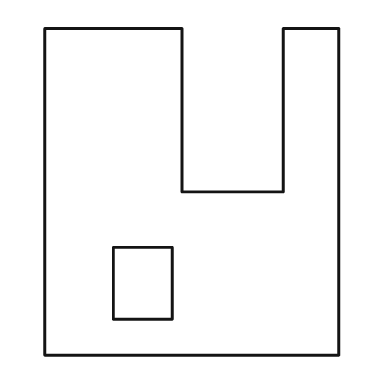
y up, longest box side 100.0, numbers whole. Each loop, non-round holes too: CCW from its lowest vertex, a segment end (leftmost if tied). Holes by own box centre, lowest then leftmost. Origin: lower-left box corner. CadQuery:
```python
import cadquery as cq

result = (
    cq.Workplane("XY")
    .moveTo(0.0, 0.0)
    .lineTo(90.0, 0.0)
    .lineTo(90.0, 100.0)
    .lineTo(73.0, 100.0)
    .lineTo(73.0, 50.0)
    .lineTo(42.0, 50.0)
    .lineTo(42.0, 100.0)
    .lineTo(0.0, 100.0)
    .close()
    .moveTo(21.0, 11.0)
    .lineTo(39.0, 11.0)
    .lineTo(39.0, 33.0)
    .lineTo(21.0, 33.0)
    .close()
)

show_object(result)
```